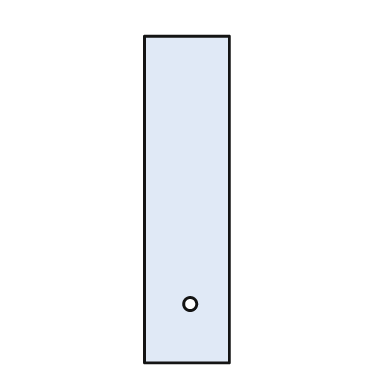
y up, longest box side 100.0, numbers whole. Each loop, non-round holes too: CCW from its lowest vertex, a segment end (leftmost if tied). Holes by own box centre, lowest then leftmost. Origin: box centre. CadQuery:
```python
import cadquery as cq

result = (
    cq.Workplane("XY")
    .moveTo(-13.0, -50.0)
    .lineTo(13.0, -50.0)
    .lineTo(13.0, 50.0)
    .lineTo(-13.0, 50.0)
    .close()
    .moveTo(1.0, -32.0)
    .circle(2.0)
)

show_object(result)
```